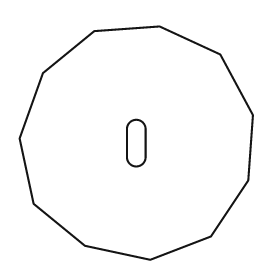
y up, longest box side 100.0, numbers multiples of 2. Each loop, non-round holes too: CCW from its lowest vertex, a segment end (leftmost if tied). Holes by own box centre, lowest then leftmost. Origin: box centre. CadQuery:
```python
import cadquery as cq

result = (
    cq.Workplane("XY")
    .moveTo(6.0, -50.0)
    .lineTo(32.0, -40.0)
    .lineTo(48.0, -16.0)
    .lineTo(50.0, 12.0)
    .lineTo(36.0, 38.0)
    .lineTo(10.0, 50.0)
    .lineTo(-18.0, 48.0)
    .lineTo(-40.0, 30.0)
    .lineTo(-50.0, 2.0)
    .lineTo(-44.0, -26.0)
    .lineTo(-22.0, -44.0)
    .close()
    .moveTo(-4.0, -6.0)
    .threePointArc((0.0, -10.0), (4.0, -6.0))
    .lineTo(4.0, 6.0)
    .threePointArc((0.0, 10.0), (-4.0, 6.0))
    .close()
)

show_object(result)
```